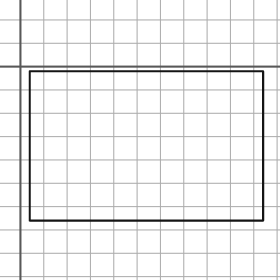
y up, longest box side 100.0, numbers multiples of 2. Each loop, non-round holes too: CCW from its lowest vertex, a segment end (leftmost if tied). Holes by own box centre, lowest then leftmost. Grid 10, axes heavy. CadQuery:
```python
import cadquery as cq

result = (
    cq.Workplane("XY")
    .moveTo(4.0, -66.0)
    .lineTo(104.0, -66.0)
    .lineTo(104.0, -2.0)
    .lineTo(4.0, -2.0)
    .close()
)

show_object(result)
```